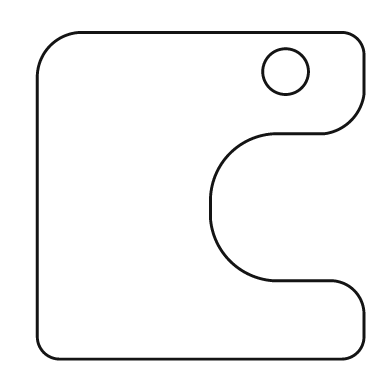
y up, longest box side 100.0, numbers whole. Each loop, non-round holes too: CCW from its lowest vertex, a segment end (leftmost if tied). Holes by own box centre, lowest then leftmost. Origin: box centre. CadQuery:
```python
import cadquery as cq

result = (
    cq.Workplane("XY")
    .moveTo(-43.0, -50.0)
    .lineTo(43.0, -50.0)
    .threePointArc((48.0, -48.0), (50.0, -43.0))
    .lineTo(50.0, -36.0)
    .threePointArc((47.0, -29.0), (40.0, -26.0))
    .lineTo(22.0, -26.0)
    .threePointArc((9.0, -20.0), (3.0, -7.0))
    .lineTo(3.0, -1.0)
    .threePointArc((9.0, 13.0), (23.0, 19.0))
    .lineTo(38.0, 19.0)
    .threePointArc((46.0, 23.0), (50.0, 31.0))
    .lineTo(50.0, 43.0)
    .threePointArc((48.0, 48.0), (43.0, 50.0))
    .lineTo(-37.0, 50.0)
    .threePointArc((-46.0, 46.0), (-50.0, 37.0))
    .lineTo(-50.0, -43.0)
    .threePointArc((-48.0, -48.0), (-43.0, -50.0))
    .close()
    .moveTo(26.0, 38.0)
    .circle(7.0)
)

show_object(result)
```